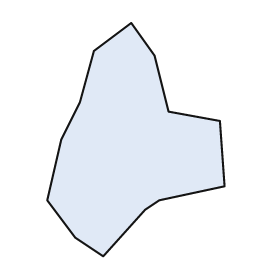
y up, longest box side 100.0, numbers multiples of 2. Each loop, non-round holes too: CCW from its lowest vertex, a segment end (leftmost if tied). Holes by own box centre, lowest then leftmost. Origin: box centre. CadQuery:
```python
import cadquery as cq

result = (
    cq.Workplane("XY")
    .moveTo(-14.0, -50.0)
    .lineTo(4.0, -30.0)
    .lineTo(10.0, -26.0)
    .lineTo(38.0, -20.0)
    .lineTo(36.0, 8.0)
    .lineTo(14.0, 12.0)
    .lineTo(8.0, 36.0)
    .lineTo(-2.0, 50.0)
    .lineTo(-18.0, 38.0)
    .lineTo(-24.0, 16.0)
    .lineTo(-32.0, 0.0)
    .lineTo(-38.0, -26.0)
    .lineTo(-26.0, -42.0)
    .close()
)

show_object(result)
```